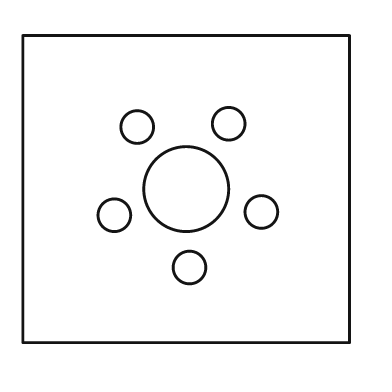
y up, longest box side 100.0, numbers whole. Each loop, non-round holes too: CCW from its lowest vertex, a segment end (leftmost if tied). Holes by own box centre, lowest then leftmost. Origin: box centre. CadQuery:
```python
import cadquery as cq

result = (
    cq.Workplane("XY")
    .moveTo(-50.0, -47.0)
    .lineTo(50.0, -47.0)
    .lineTo(50.0, 47.0)
    .lineTo(-50.0, 47.0)
    .close()
    .moveTo(1.0, -24.0)
    .circle(5.0)
    .moveTo(-22.0, -8.0)
    .circle(5.0)
    .moveTo(23.0, -7.0)
    .circle(5.0)
    .moveTo(0.0, 0.0)
    .circle(13.0)
    .moveTo(-15.0, 19.0)
    .circle(5.0)
    .moveTo(13.0, 20.0)
    .circle(5.0)
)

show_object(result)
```